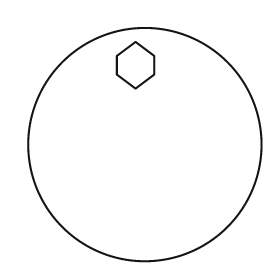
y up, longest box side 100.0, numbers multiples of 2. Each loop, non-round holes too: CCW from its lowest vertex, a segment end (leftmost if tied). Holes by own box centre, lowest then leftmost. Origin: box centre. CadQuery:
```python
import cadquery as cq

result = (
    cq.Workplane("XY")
    .moveTo(0.0, 0.0)
    .circle(50.0)
    .moveTo(-4.0, 24.0)
    .lineTo(4.0, 30.0)
    .lineTo(4.0, 38.0)
    .lineTo(-4.0, 44.0)
    .lineTo(-12.0, 38.0)
    .lineTo(-12.0, 30.0)
    .close()
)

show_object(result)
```